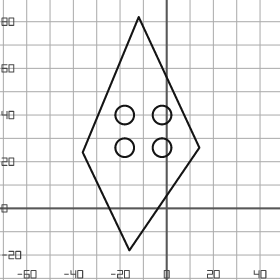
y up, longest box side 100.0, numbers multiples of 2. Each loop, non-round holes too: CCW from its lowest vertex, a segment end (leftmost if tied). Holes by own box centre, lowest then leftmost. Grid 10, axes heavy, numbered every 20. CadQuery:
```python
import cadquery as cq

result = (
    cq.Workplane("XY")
    .moveTo(-16.0, -18.0)
    .lineTo(14.0, 26.0)
    .lineTo(-12.0, 82.0)
    .lineTo(-36.0, 24.0)
    .close()
    .moveTo(-18.0, 26.0)
    .circle(4.0)
    .moveTo(-2.0, 26.0)
    .circle(4.0)
    .moveTo(-18.0, 40.0)
    .circle(4.0)
    .moveTo(-2.0, 40.0)
    .circle(4.0)
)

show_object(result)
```